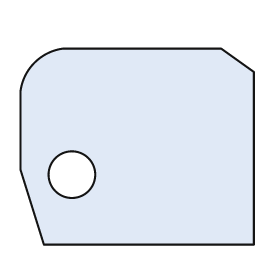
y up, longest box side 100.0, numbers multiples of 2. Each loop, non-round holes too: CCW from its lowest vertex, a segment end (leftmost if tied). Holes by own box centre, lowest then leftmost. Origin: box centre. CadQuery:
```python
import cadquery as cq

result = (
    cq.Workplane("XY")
    .moveTo(-40.0, -42.0)
    .lineTo(50.0, -42.0)
    .lineTo(50.0, 32.0)
    .lineTo(36.0, 42.0)
    .lineTo(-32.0, 42.0)
    .threePointArc((-44.0, 36.0), (-50.0, 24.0))
    .lineTo(-50.0, -10.0)
    .close()
    .moveTo(-28.0, -12.0)
    .circle(10.0)
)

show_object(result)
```